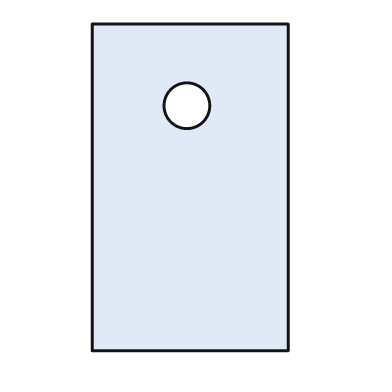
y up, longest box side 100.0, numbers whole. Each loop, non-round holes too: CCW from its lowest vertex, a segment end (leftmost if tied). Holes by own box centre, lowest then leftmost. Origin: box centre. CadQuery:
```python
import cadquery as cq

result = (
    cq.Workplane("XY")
    .moveTo(-30.0, -50.0)
    .lineTo(30.0, -50.0)
    .lineTo(30.0, 50.0)
    .lineTo(-30.0, 50.0)
    .close()
    .moveTo(-1.0, 25.0)
    .circle(7.0)
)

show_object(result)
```